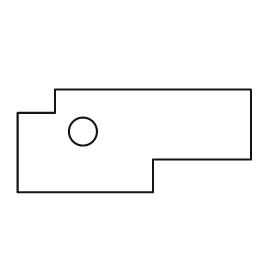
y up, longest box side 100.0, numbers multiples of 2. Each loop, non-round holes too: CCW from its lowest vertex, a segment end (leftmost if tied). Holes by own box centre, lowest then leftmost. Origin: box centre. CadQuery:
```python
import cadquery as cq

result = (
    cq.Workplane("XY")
    .moveTo(-50.0, -22.0)
    .lineTo(8.0, -22.0)
    .lineTo(8.0, -8.0)
    .lineTo(50.0, -8.0)
    .lineTo(50.0, 22.0)
    .lineTo(-34.0, 22.0)
    .lineTo(-34.0, 12.0)
    .lineTo(-50.0, 12.0)
    .close()
    .moveTo(-22.0, 4.0)
    .circle(6.0)
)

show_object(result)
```